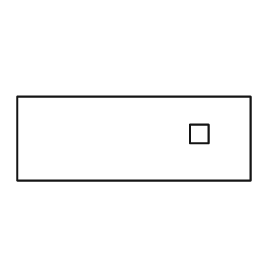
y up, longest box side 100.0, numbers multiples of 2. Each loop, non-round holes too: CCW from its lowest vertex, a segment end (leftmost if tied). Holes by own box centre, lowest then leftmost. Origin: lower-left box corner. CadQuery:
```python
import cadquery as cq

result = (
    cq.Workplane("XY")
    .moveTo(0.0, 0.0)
    .lineTo(100.0, 0.0)
    .lineTo(100.0, 36.0)
    .lineTo(0.0, 36.0)
    .close()
    .moveTo(74.0, 16.0)
    .lineTo(82.0, 16.0)
    .lineTo(82.0, 24.0)
    .lineTo(74.0, 24.0)
    .close()
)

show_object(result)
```